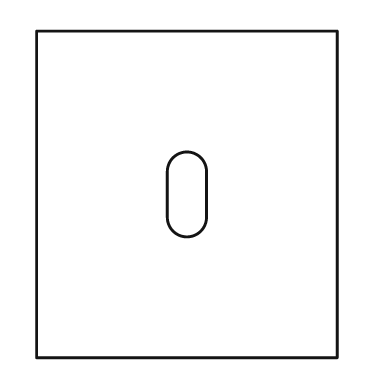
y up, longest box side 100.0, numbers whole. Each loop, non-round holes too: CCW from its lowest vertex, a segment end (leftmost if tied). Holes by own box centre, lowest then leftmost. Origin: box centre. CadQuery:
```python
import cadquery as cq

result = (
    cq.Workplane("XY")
    .moveTo(-46.0, -50.0)
    .lineTo(46.0, -50.0)
    .lineTo(46.0, 50.0)
    .lineTo(-46.0, 50.0)
    .close()
    .moveTo(-6.0, -7.0)
    .threePointArc((0.0, -13.0), (6.0, -7.0))
    .lineTo(6.0, 7.0)
    .threePointArc((0.0, 13.0), (-6.0, 7.0))
    .close()
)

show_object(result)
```